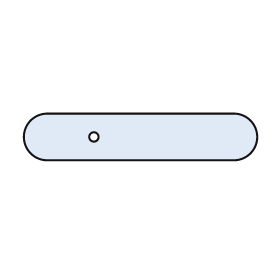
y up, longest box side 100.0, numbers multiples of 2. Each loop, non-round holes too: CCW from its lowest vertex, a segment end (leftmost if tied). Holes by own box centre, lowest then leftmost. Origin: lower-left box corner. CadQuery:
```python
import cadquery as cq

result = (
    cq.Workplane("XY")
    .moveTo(10.0, 0.0)
    .lineTo(90.0, 0.0)
    .threePointArc((100.0, 10.0), (90.0, 20.0))
    .lineTo(10.0, 20.0)
    .threePointArc((0.0, 10.0), (10.0, 0.0))
    .close()
    .moveTo(30.0, 10.0)
    .circle(2.0)
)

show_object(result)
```